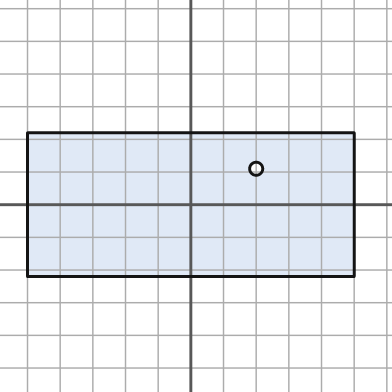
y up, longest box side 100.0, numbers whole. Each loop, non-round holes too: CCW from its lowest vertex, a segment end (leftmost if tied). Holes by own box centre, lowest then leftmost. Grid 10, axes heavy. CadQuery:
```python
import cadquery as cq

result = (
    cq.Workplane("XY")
    .moveTo(-50.0, -22.0)
    .lineTo(50.0, -22.0)
    .lineTo(50.0, 22.0)
    .lineTo(-50.0, 22.0)
    .close()
    .moveTo(20.0, 11.0)
    .circle(2.0)
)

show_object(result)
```